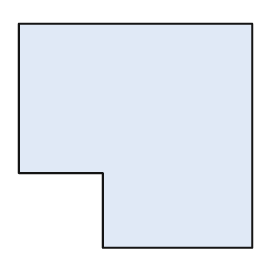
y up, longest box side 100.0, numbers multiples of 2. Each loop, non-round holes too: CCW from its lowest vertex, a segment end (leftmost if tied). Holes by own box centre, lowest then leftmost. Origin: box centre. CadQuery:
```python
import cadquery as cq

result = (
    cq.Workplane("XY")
    .moveTo(-14.0, -48.0)
    .lineTo(50.0, -48.0)
    .lineTo(50.0, 48.0)
    .lineTo(-50.0, 48.0)
    .lineTo(-50.0, -16.0)
    .lineTo(-14.0, -16.0)
    .close()
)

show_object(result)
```